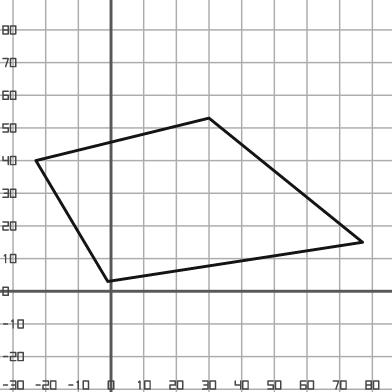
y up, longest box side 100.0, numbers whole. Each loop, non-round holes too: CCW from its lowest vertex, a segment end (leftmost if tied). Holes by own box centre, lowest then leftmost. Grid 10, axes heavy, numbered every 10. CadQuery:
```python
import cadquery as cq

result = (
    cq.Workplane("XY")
    .moveTo(-1.0, 3.0)
    .lineTo(77.0, 15.0)
    .lineTo(30.0, 53.0)
    .lineTo(-23.0, 40.0)
    .close()
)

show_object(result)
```